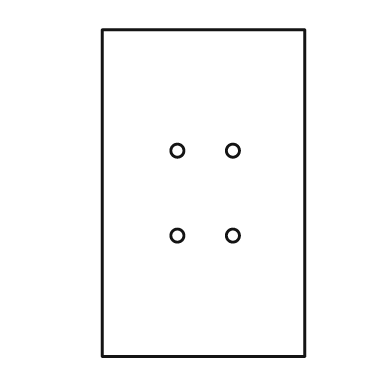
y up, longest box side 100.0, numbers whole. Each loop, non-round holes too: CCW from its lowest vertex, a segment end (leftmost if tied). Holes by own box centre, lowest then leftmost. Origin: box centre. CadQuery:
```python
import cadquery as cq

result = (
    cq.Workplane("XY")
    .moveTo(-31.0, -50.0)
    .lineTo(31.0, -50.0)
    .lineTo(31.0, 50.0)
    .lineTo(-31.0, 50.0)
    .close()
    .moveTo(-8.0, -13.0)
    .circle(2.0)
    .moveTo(9.0, -13.0)
    .circle(2.0)
    .moveTo(-8.0, 13.0)
    .circle(2.0)
    .moveTo(9.0, 13.0)
    .circle(2.0)
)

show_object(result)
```